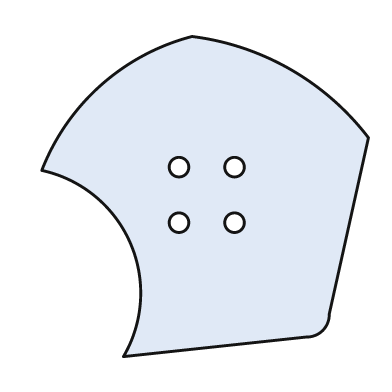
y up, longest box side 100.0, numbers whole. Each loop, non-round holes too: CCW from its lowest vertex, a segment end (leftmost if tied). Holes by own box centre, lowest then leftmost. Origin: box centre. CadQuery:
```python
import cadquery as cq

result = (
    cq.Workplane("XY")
    .moveTo(-25.0, -49.0)
    .lineTo(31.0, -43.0)
    .threePointArc((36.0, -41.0), (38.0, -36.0))
    .lineTo(50.0, 18.0)
    .threePointArc((26.0, 39.0), (-4.0, 49.0))
    .threePointArc((-32.0, 34.0), (-50.0, 8.0))
    .threePointArc((-23.0, -14.0), (-25.0, -49.0))
    .close()
    .moveTo(-8.0, -8.0)
    .circle(3.0)
    .moveTo(9.0, -8.0)
    .circle(3.0)
    .moveTo(-8.0, 9.0)
    .circle(3.0)
    .moveTo(9.0, 9.0)
    .circle(3.0)
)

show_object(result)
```